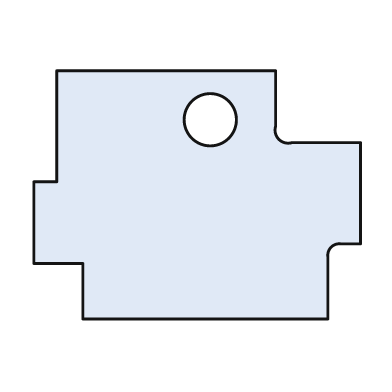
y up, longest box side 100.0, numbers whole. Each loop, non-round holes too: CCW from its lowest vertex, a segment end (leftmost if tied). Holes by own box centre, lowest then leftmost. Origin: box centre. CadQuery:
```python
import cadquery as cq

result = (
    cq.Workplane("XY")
    .moveTo(-35.0, -38.0)
    .lineTo(40.0, -38.0)
    .lineTo(40.0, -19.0)
    .threePointArc((41.0, -16.0), (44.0, -15.0))
    .lineTo(50.0, -15.0)
    .lineTo(50.0, 16.0)
    .lineTo(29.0, 16.0)
    .threePointArc((25.0, 17.0), (24.0, 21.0))
    .lineTo(24.0, 38.0)
    .lineTo(-43.0, 38.0)
    .lineTo(-43.0, 4.0)
    .lineTo(-50.0, 4.0)
    .lineTo(-50.0, -21.0)
    .lineTo(-35.0, -21.0)
    .close()
    .moveTo(4.0, 23.0)
    .circle(8.0)
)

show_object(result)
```